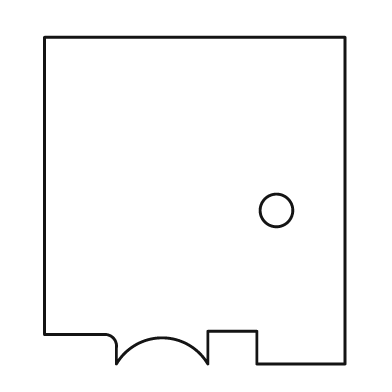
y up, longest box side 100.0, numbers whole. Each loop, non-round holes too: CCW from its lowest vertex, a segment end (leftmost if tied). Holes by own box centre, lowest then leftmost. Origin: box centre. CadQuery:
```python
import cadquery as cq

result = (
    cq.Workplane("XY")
    .moveTo(-24.0, -50.0)
    .threePointArc((-10.0, -42.0), (4.0, -50.0))
    .lineTo(4.0, -40.0)
    .lineTo(19.0, -40.0)
    .lineTo(19.0, -50.0)
    .lineTo(46.0, -50.0)
    .lineTo(46.0, 50.0)
    .lineTo(-46.0, 50.0)
    .lineTo(-46.0, -41.0)
    .lineTo(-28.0, -41.0)
    .threePointArc((-25.0, -42.0), (-24.0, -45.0))
    .close()
    .moveTo(25.0, -3.0)
    .circle(5.0)
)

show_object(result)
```